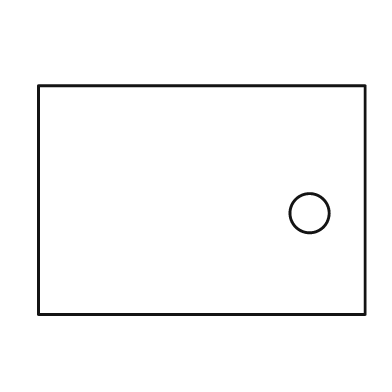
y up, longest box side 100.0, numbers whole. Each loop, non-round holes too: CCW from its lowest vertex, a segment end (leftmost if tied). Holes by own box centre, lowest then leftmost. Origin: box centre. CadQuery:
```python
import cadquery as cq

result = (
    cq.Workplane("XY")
    .moveTo(-50.0, -35.0)
    .lineTo(50.0, -35.0)
    .lineTo(50.0, 35.0)
    .lineTo(-50.0, 35.0)
    .close()
    .moveTo(33.0, -4.0)
    .circle(6.0)
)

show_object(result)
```